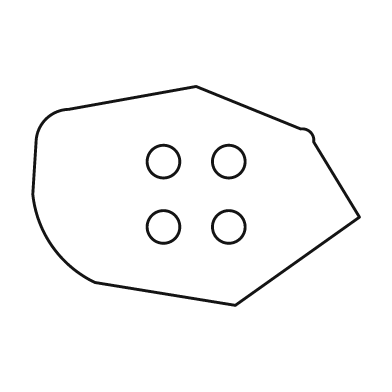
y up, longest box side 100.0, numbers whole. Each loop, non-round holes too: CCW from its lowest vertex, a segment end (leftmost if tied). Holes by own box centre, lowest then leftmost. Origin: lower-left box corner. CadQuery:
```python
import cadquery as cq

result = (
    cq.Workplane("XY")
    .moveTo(62.0, 0.0)
    .lineTo(100.0, 27.0)
    .lineTo(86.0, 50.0)
    .threePointArc((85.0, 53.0), (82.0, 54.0))
    .lineTo(50.0, 67.0)
    .lineTo(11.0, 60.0)
    .threePointArc((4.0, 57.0), (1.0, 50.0))
    .lineTo(0.0, 34.0)
    .threePointArc((6.0, 18.0), (19.0, 7.0))
    .close()
    .moveTo(40.0, 24.0)
    .circle(5.0)
    .moveTo(60.0, 24.0)
    .circle(5.0)
    .moveTo(40.0, 44.0)
    .circle(5.0)
    .moveTo(60.0, 44.0)
    .circle(5.0)
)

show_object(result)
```